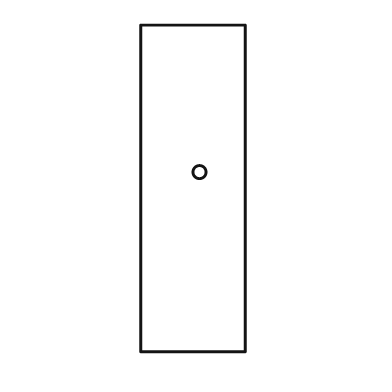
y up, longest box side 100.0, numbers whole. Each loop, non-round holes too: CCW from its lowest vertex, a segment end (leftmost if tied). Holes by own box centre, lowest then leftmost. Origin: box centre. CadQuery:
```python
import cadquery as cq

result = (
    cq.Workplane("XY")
    .moveTo(-16.0, -50.0)
    .lineTo(16.0, -50.0)
    .lineTo(16.0, 50.0)
    .lineTo(-16.0, 50.0)
    .close()
    .moveTo(2.0, 5.0)
    .circle(2.0)
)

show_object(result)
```